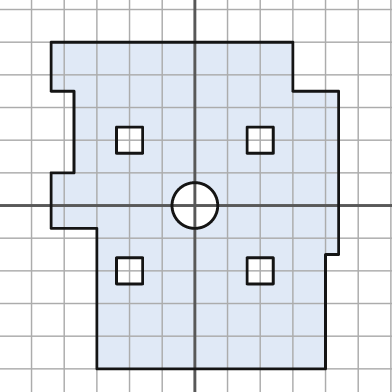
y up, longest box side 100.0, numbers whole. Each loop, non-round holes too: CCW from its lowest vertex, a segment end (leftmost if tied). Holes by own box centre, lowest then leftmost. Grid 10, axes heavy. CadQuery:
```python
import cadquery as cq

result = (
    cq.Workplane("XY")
    .moveTo(-30.0, -50.0)
    .lineTo(40.0, -50.0)
    .lineTo(40.0, -15.0)
    .lineTo(44.0, -15.0)
    .lineTo(44.0, 35.0)
    .lineTo(30.0, 35.0)
    .lineTo(30.0, 50.0)
    .lineTo(-44.0, 50.0)
    .lineTo(-44.0, 35.0)
    .lineTo(-37.0, 35.0)
    .lineTo(-37.0, 10.0)
    .lineTo(-44.0, 10.0)
    .lineTo(-44.0, -7.0)
    .lineTo(-30.0, -7.0)
    .close()
    .moveTo(-24.0, -24.0)
    .lineTo(-16.0, -24.0)
    .lineTo(-16.0, -16.0)
    .lineTo(-24.0, -16.0)
    .close()
    .moveTo(16.0, -24.0)
    .lineTo(24.0, -24.0)
    .lineTo(24.0, -16.0)
    .lineTo(16.0, -16.0)
    .close()
    .moveTo(0.0, 0.0)
    .circle(7.0)
    .moveTo(-24.0, 16.0)
    .lineTo(-16.0, 16.0)
    .lineTo(-16.0, 24.0)
    .lineTo(-24.0, 24.0)
    .close()
    .moveTo(16.0, 16.0)
    .lineTo(24.0, 16.0)
    .lineTo(24.0, 24.0)
    .lineTo(16.0, 24.0)
    .close()
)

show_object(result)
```